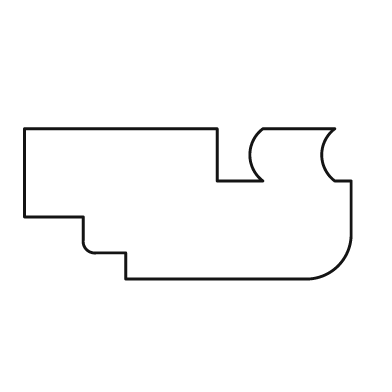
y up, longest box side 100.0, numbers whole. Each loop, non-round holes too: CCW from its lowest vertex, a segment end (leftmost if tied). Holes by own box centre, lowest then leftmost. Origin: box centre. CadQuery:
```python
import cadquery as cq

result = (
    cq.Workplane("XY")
    .moveTo(-19.0, -23.0)
    .lineTo(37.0, -23.0)
    .threePointArc((46.0, -19.0), (50.0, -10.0))
    .lineTo(50.0, 7.0)
    .lineTo(45.0, 7.0)
    .threePointArc((41.0, 15.0), (45.0, 23.0))
    .lineTo(23.0, 23.0)
    .threePointArc((19.0, 15.0), (23.0, 7.0))
    .lineTo(9.0, 7.0)
    .lineTo(9.0, 23.0)
    .lineTo(-50.0, 23.0)
    .lineTo(-50.0, -4.0)
    .lineTo(-32.0, -4.0)
    .lineTo(-32.0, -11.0)
    .threePointArc((-31.0, -14.0), (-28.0, -15.0))
    .lineTo(-19.0, -15.0)
    .close()
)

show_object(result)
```